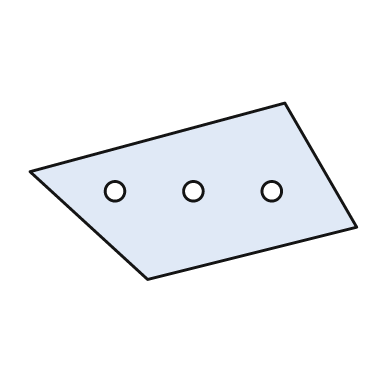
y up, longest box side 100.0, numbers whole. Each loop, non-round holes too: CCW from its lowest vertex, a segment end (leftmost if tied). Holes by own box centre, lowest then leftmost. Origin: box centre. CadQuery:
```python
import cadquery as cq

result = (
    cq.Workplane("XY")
    .moveTo(-14.0, -27.0)
    .lineTo(50.0, -11.0)
    .lineTo(28.0, 27.0)
    .lineTo(-50.0, 6.0)
    .close()
    .moveTo(-24.0, 0.0)
    .circle(3.0)
    .moveTo(0.0, 0.0)
    .circle(3.0)
    .moveTo(24.0, 0.0)
    .circle(3.0)
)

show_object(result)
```